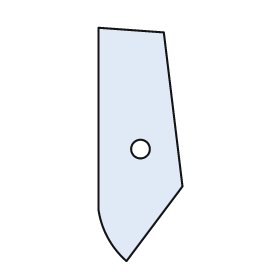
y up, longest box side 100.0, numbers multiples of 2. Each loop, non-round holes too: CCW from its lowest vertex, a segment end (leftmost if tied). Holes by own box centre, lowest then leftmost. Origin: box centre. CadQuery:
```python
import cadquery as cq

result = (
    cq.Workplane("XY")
    .moveTo(-6.0, -50.0)
    .lineTo(18.0, -18.0)
    .lineTo(10.0, 48.0)
    .lineTo(-18.0, 50.0)
    .lineTo(-18.0, -28.0)
    .threePointArc((-14.0, -40.0), (-6.0, -50.0))
    .close()
    .moveTo(0.0, -2.0)
    .circle(4.0)
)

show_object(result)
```